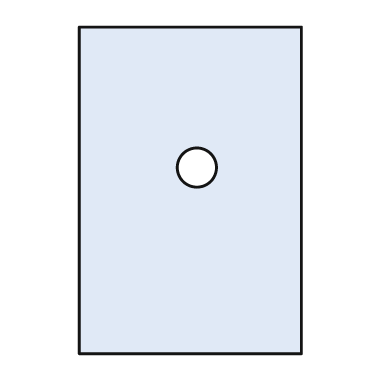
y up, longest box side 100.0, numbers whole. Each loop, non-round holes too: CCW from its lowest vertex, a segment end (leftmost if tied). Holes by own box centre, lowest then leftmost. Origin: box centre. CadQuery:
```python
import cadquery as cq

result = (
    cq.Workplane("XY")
    .moveTo(-34.0, -50.0)
    .lineTo(34.0, -50.0)
    .lineTo(34.0, 50.0)
    .lineTo(-34.0, 50.0)
    .close()
    .moveTo(2.0, 7.0)
    .circle(6.0)
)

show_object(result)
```